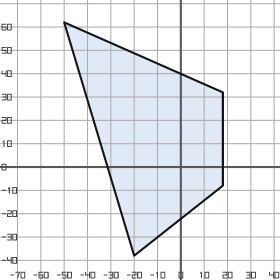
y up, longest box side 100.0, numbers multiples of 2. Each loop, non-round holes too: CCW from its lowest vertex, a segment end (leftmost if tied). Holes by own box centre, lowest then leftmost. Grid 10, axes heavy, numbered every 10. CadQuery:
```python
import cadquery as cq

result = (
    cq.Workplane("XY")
    .moveTo(-20.0, -38.0)
    .lineTo(18.0, -8.0)
    .lineTo(18.0, 32.0)
    .lineTo(-50.0, 62.0)
    .close()
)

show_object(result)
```